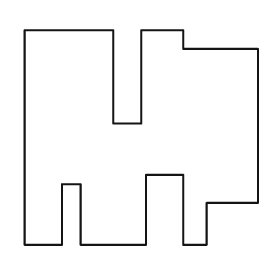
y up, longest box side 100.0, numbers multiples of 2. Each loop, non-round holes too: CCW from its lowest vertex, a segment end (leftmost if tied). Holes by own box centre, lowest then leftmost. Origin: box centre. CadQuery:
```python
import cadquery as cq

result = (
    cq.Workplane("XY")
    .moveTo(-50.0, -46.0)
    .lineTo(-34.0, -46.0)
    .lineTo(-34.0, -20.0)
    .lineTo(-26.0, -20.0)
    .lineTo(-26.0, -46.0)
    .lineTo(2.0, -46.0)
    .lineTo(2.0, -16.0)
    .lineTo(18.0, -16.0)
    .lineTo(18.0, -46.0)
    .lineTo(28.0, -46.0)
    .lineTo(28.0, -28.0)
    .lineTo(50.0, -28.0)
    .lineTo(50.0, 38.0)
    .lineTo(18.0, 38.0)
    .lineTo(18.0, 46.0)
    .lineTo(0.0, 46.0)
    .lineTo(0.0, 6.0)
    .lineTo(-12.0, 6.0)
    .lineTo(-12.0, 46.0)
    .lineTo(-50.0, 46.0)
    .close()
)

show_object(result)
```